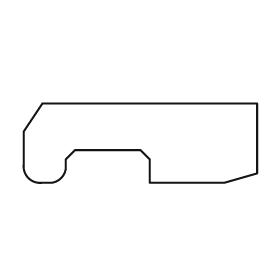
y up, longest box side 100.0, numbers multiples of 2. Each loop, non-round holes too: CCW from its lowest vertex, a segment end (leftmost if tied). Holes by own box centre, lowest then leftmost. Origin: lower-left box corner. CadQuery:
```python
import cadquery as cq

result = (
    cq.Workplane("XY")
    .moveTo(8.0, 0.0)
    .lineTo(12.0, 0.0)
    .threePointArc((16.0, 2.0), (18.0, 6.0))
    .lineTo(18.0, 10.0)
    .lineTo(22.0, 14.0)
    .lineTo(50.0, 14.0)
    .lineTo(54.0, 10.0)
    .lineTo(54.0, 0.0)
    .lineTo(86.0, 0.0)
    .lineTo(100.0, 4.0)
    .lineTo(100.0, 34.0)
    .lineTo(8.0, 34.0)
    .lineTo(0.0, 22.0)
    .lineTo(0.0, 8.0)
    .threePointArc((2.0, 2.0), (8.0, 0.0))
    .close()
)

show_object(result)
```